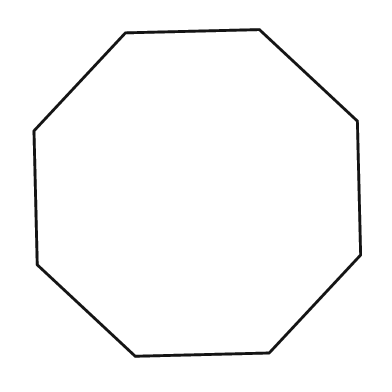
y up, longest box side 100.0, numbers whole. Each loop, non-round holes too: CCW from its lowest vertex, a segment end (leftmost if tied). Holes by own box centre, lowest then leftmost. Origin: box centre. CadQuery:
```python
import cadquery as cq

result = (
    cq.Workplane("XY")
    .moveTo(-19.0, -50.0)
    .lineTo(22.0, -49.0)
    .lineTo(50.0, -19.0)
    .lineTo(49.0, 22.0)
    .lineTo(19.0, 50.0)
    .lineTo(-22.0, 49.0)
    .lineTo(-50.0, 19.0)
    .lineTo(-49.0, -22.0)
    .close()
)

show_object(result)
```